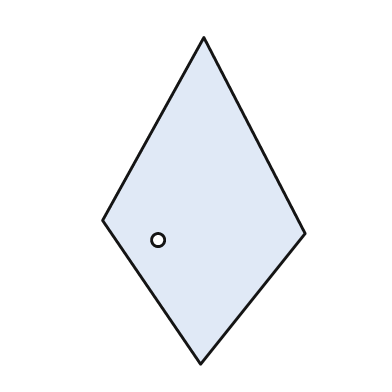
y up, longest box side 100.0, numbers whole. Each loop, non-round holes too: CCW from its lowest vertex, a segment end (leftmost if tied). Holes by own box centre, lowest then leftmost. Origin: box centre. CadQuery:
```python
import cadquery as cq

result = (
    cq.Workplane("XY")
    .moveTo(-1.0, -50.0)
    .lineTo(31.0, -10.0)
    .lineTo(0.0, 50.0)
    .lineTo(-31.0, -6.0)
    .close()
    .moveTo(-14.0, -12.0)
    .circle(2.0)
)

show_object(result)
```